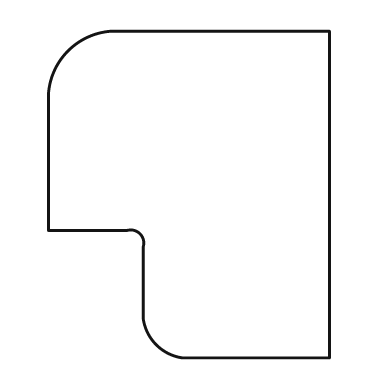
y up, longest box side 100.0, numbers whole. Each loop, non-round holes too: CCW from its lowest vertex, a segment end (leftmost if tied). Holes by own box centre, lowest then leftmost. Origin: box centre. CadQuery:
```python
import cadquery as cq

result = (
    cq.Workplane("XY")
    .moveTo(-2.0, -50.0)
    .lineTo(43.0, -50.0)
    .lineTo(43.0, 50.0)
    .lineTo(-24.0, 50.0)
    .threePointArc((-37.0, 44.0), (-43.0, 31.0))
    .lineTo(-43.0, -11.0)
    .lineTo(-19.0, -11.0)
    .threePointArc((-15.0, -12.0), (-14.0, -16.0))
    .lineTo(-14.0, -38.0)
    .threePointArc((-10.0, -46.0), (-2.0, -50.0))
    .close()
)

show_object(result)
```